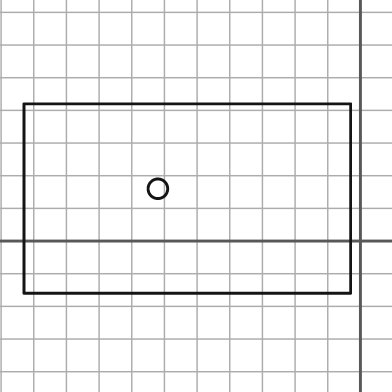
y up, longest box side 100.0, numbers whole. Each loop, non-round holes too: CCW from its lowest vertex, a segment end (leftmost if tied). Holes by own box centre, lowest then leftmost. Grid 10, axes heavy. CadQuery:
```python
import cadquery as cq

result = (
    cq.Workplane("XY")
    .moveTo(-103.0, -16.0)
    .lineTo(-3.0, -16.0)
    .lineTo(-3.0, 42.0)
    .lineTo(-103.0, 42.0)
    .close()
    .moveTo(-62.0, 16.0)
    .circle(3.0)
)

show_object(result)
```